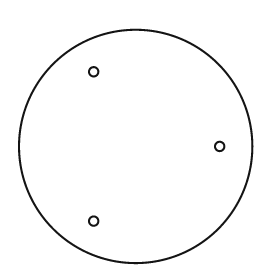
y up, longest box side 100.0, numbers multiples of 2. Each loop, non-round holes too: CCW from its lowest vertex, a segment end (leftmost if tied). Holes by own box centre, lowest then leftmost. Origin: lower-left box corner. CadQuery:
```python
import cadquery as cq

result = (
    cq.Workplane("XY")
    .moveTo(50.0, 50.0)
    .circle(50.0)
    .moveTo(32.0, 18.0)
    .circle(2.0)
    .moveTo(86.0, 50.0)
    .circle(2.0)
    .moveTo(32.0, 82.0)
    .circle(2.0)
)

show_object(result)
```